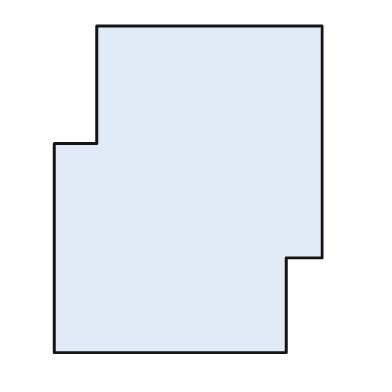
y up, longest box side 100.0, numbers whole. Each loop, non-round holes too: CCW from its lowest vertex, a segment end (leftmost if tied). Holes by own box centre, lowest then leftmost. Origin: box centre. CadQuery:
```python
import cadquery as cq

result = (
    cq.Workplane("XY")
    .moveTo(-41.0, -50.0)
    .lineTo(30.0, -50.0)
    .lineTo(30.0, -21.0)
    .lineTo(41.0, -21.0)
    .lineTo(41.0, 50.0)
    .lineTo(-28.0, 50.0)
    .lineTo(-28.0, 14.0)
    .lineTo(-41.0, 14.0)
    .close()
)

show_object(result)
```